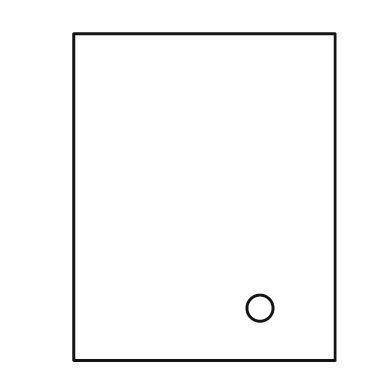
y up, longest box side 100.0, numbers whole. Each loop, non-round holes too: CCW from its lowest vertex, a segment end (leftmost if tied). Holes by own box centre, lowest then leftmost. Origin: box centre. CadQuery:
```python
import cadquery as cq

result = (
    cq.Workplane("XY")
    .moveTo(-40.0, -50.0)
    .lineTo(40.0, -50.0)
    .lineTo(40.0, 50.0)
    .lineTo(-40.0, 50.0)
    .close()
    .moveTo(17.0, -34.0)
    .circle(4.0)
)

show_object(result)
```